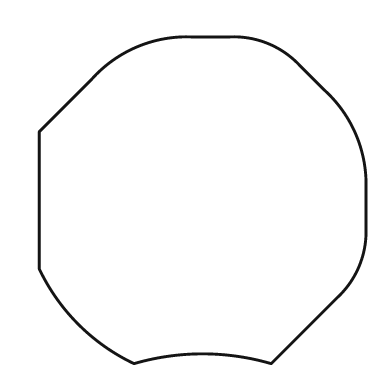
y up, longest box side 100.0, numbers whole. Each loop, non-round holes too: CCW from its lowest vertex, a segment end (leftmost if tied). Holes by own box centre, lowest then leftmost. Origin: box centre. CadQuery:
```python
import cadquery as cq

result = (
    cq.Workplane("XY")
    .moveTo(-21.0, -50.0)
    .threePointArc((0.0, -47.0), (21.0, -50.0))
    .lineTo(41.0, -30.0)
    .threePointArc((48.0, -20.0), (50.0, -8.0))
    .lineTo(50.0, 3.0)
    .threePointArc((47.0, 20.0), (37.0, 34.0))
    .lineTo(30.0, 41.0)
    .threePointArc((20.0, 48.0), (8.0, 50.0))
    .lineTo(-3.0, 50.0)
    .threePointArc((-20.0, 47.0), (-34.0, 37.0))
    .lineTo(-50.0, 21.0)
    .lineTo(-50.0, -21.0)
    .threePointArc((-38.0, -38.0), (-21.0, -50.0))
    .close()
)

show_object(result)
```